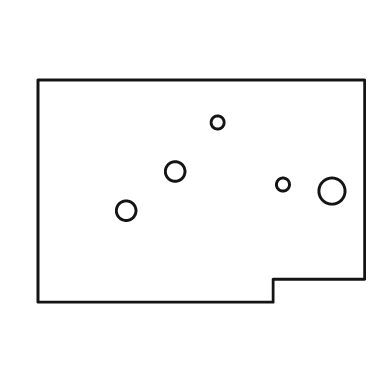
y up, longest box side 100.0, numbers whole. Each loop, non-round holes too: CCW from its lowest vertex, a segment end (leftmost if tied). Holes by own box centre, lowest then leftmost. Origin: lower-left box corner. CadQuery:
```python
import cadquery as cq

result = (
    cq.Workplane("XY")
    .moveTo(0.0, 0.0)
    .lineTo(72.0, 0.0)
    .lineTo(72.0, 7.0)
    .lineTo(100.0, 7.0)
    .lineTo(100.0, 68.0)
    .lineTo(0.0, 68.0)
    .close()
    .moveTo(27.0, 28.0)
    .circle(3.0)
    .moveTo(90.0, 34.0)
    .circle(4.0)
    .moveTo(75.0, 36.0)
    .circle(2.0)
    .moveTo(42.0, 40.0)
    .circle(3.0)
    .moveTo(55.0, 55.0)
    .circle(2.0)
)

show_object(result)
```